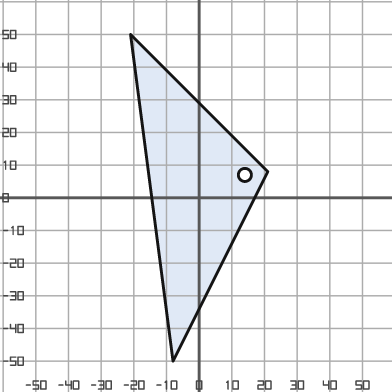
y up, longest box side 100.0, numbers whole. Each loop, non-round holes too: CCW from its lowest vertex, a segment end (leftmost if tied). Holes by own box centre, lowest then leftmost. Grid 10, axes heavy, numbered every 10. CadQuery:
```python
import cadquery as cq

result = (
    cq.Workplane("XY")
    .moveTo(-8.0, -50.0)
    .lineTo(21.0, 8.0)
    .lineTo(-21.0, 50.0)
    .close()
    .moveTo(14.0, 7.0)
    .circle(2.0)
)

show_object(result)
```